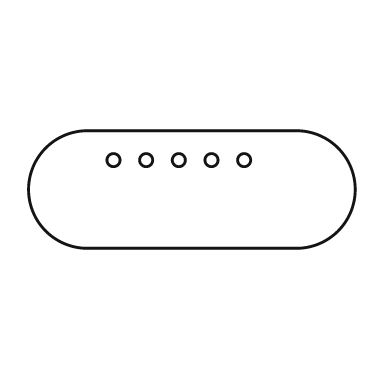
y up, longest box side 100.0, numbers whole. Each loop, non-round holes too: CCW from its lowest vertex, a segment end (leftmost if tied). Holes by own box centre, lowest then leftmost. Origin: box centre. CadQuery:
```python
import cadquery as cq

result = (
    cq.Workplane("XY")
    .moveTo(-32.0, -18.0)
    .lineTo(32.0, -18.0)
    .threePointArc((50.0, 0.0), (32.0, 18.0))
    .lineTo(-32.0, 18.0)
    .threePointArc((-50.0, 0.0), (-32.0, -18.0))
    .close()
    .moveTo(-24.0, 9.0)
    .circle(2.0)
    .moveTo(-14.0, 9.0)
    .circle(2.0)
    .moveTo(-4.0, 9.0)
    .circle(2.0)
    .moveTo(6.0, 9.0)
    .circle(2.0)
    .moveTo(16.0, 9.0)
    .circle(2.0)
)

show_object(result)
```